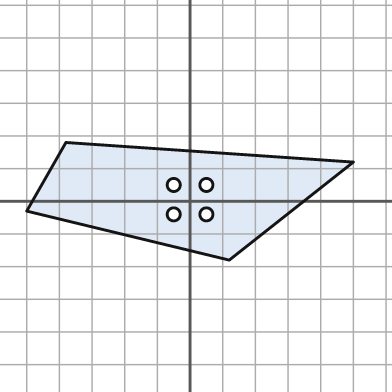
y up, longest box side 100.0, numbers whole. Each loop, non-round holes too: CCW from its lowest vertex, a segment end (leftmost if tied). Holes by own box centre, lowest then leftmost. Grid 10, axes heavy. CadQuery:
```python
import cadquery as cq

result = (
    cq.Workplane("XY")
    .moveTo(12.0, -18.0)
    .lineTo(50.0, 12.0)
    .lineTo(-38.0, 18.0)
    .lineTo(-50.0, -3.0)
    .close()
    .moveTo(-5.0, -4.0)
    .circle(2.0)
    .moveTo(5.0, -4.0)
    .circle(2.0)
    .moveTo(-5.0, 5.0)
    .circle(2.0)
    .moveTo(5.0, 5.0)
    .circle(2.0)
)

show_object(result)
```